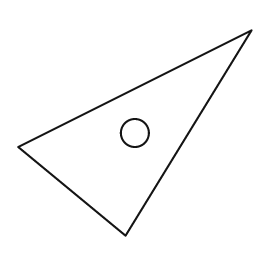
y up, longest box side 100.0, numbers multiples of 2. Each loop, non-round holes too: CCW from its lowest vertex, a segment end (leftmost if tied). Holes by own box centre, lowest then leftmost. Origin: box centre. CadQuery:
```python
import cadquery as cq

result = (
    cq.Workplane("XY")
    .moveTo(-4.0, -44.0)
    .lineTo(50.0, 44.0)
    .lineTo(-50.0, -6.0)
    .close()
    .moveTo(0.0, 0.0)
    .circle(6.0)
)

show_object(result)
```